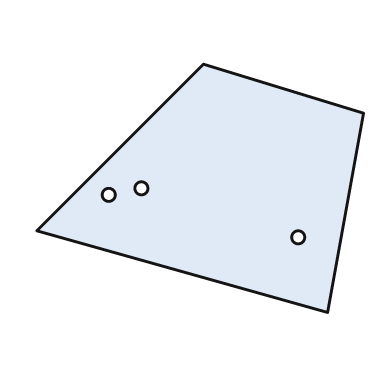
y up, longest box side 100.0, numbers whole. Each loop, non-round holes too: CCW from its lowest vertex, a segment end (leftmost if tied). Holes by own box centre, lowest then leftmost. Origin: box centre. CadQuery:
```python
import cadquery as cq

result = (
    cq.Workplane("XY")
    .moveTo(39.0, -38.0)
    .lineTo(50.0, 23.0)
    .lineTo(1.0, 38.0)
    .lineTo(-50.0, -13.0)
    .close()
    .moveTo(30.0, -15.0)
    .circle(2.0)
    .moveTo(-28.0, -2.0)
    .circle(2.0)
    .moveTo(-18.0, 0.0)
    .circle(2.0)
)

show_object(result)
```